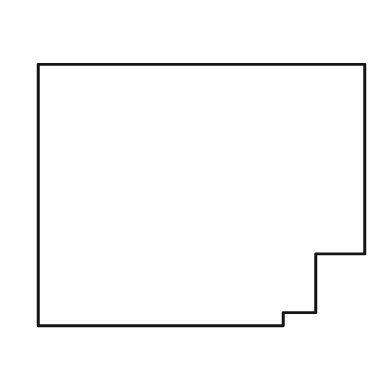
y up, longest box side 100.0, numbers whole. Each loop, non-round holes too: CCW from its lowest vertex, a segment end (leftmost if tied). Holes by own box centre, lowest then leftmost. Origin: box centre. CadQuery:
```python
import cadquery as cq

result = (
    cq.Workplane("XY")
    .moveTo(-50.0, -40.0)
    .lineTo(25.0, -40.0)
    .lineTo(25.0, -36.0)
    .lineTo(35.0, -36.0)
    .lineTo(35.0, -18.0)
    .lineTo(50.0, -18.0)
    .lineTo(50.0, 40.0)
    .lineTo(-50.0, 40.0)
    .close()
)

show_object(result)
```